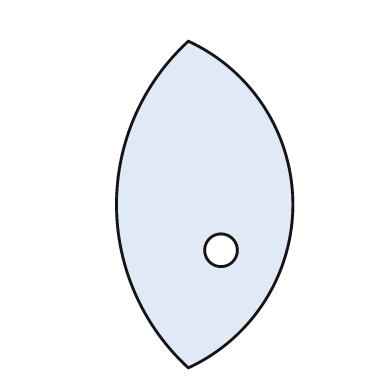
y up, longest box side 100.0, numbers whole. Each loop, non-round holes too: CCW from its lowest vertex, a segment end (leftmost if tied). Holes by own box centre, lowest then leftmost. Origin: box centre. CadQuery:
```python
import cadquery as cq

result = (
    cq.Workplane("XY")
    .moveTo(-5.0, -50.0)
    .threePointArc((27.0, 0.0), (-5.0, 50.0))
    .threePointArc((-27.0, 0.0), (-5.0, -50.0))
    .close()
    .moveTo(5.0, -14.0)
    .circle(5.0)
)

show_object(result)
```